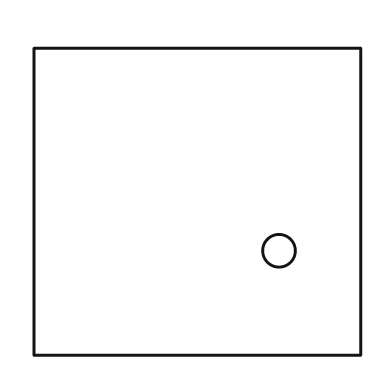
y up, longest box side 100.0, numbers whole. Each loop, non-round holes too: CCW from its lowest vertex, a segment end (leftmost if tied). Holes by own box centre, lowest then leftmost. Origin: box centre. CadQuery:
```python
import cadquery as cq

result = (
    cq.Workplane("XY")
    .moveTo(-50.0, -47.0)
    .lineTo(50.0, -47.0)
    .lineTo(50.0, 47.0)
    .lineTo(-50.0, 47.0)
    .close()
    .moveTo(25.0, -15.0)
    .circle(5.0)
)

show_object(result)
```